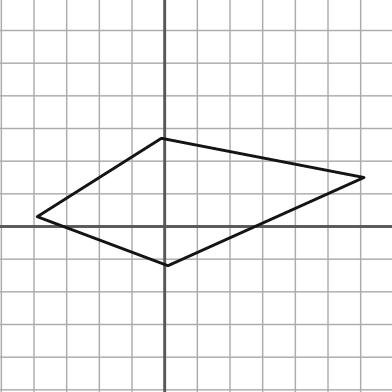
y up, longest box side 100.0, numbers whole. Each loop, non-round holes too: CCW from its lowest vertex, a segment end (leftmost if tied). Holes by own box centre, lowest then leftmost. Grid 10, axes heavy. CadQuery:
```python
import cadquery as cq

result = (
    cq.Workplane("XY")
    .moveTo(1.0, -12.0)
    .lineTo(61.0, 15.0)
    .lineTo(-1.0, 27.0)
    .lineTo(-39.0, 3.0)
    .close()
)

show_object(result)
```